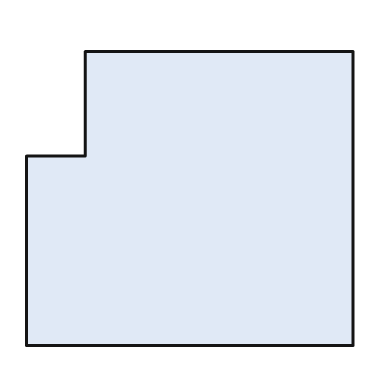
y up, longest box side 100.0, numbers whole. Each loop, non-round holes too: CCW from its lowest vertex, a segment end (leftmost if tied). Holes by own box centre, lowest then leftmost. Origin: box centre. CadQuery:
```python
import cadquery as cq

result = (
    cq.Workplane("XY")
    .moveTo(-50.0, -45.0)
    .lineTo(50.0, -45.0)
    .lineTo(50.0, 45.0)
    .lineTo(-32.0, 45.0)
    .lineTo(-32.0, 13.0)
    .lineTo(-50.0, 13.0)
    .close()
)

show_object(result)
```